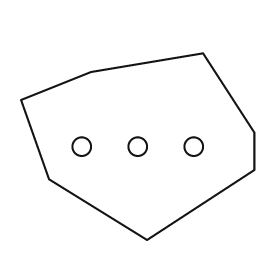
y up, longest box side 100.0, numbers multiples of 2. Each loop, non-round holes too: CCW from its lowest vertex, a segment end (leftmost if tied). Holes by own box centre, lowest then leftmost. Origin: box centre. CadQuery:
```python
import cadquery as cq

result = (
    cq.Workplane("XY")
    .moveTo(4.0, -40.0)
    .lineTo(50.0, -10.0)
    .lineTo(50.0, 6.0)
    .lineTo(28.0, 40.0)
    .lineTo(-20.0, 32.0)
    .lineTo(-50.0, 20.0)
    .lineTo(-38.0, -14.0)
    .close()
    .moveTo(-24.0, 0.0)
    .circle(4.0)
    .moveTo(0.0, 0.0)
    .circle(4.0)
    .moveTo(24.0, 0.0)
    .circle(4.0)
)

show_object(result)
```